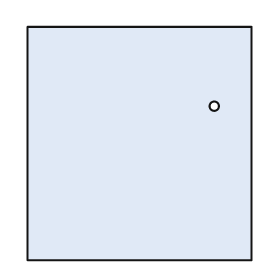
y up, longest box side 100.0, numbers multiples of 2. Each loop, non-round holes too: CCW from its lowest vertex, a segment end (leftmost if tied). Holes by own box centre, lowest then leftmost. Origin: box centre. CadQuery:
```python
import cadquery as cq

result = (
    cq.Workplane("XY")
    .moveTo(-48.0, -50.0)
    .lineTo(48.0, -50.0)
    .lineTo(48.0, 50.0)
    .lineTo(-48.0, 50.0)
    .close()
    .moveTo(32.0, 16.0)
    .circle(2.0)
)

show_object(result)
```